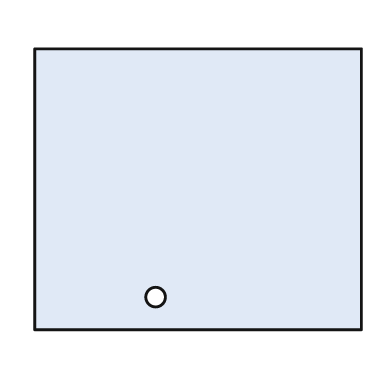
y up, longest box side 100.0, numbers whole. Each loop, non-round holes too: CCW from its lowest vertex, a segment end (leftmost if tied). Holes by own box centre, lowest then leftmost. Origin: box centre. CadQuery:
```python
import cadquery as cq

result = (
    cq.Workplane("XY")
    .moveTo(-50.0, -43.0)
    .lineTo(50.0, -43.0)
    .lineTo(50.0, 43.0)
    .lineTo(-50.0, 43.0)
    .close()
    .moveTo(-13.0, -33.0)
    .circle(3.0)
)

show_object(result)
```